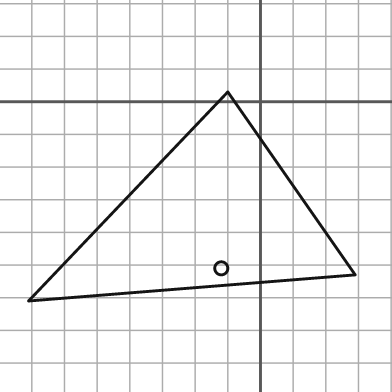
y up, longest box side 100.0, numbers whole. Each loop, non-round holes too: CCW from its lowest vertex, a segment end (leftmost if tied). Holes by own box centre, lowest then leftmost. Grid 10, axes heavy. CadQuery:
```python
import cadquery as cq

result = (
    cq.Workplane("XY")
    .moveTo(-71.0, -61.0)
    .lineTo(29.0, -53.0)
    .lineTo(-10.0, 3.0)
    .close()
    .moveTo(-12.0, -51.0)
    .circle(2.0)
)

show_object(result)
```